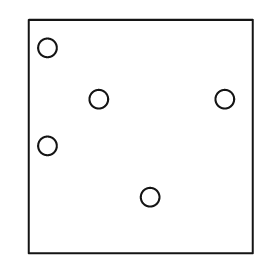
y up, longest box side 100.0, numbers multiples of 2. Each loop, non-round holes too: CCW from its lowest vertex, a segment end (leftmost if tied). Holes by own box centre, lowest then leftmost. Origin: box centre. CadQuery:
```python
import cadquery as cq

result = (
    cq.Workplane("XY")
    .moveTo(-48.0, -50.0)
    .lineTo(48.0, -50.0)
    .lineTo(48.0, 50.0)
    .lineTo(-48.0, 50.0)
    .close()
    .moveTo(4.0, -26.0)
    .circle(4.0)
    .moveTo(-40.0, -4.0)
    .circle(4.0)
    .moveTo(-18.0, 16.0)
    .circle(4.0)
    .moveTo(36.0, 16.0)
    .circle(4.0)
    .moveTo(-40.0, 38.0)
    .circle(4.0)
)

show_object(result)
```